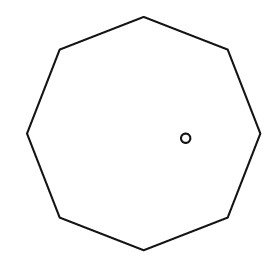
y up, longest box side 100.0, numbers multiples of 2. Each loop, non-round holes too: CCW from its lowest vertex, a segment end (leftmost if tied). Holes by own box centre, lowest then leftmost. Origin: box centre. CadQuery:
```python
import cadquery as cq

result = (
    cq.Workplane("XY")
    .moveTo(0.0, -50.0)
    .lineTo(36.0, -36.0)
    .lineTo(50.0, 0.0)
    .lineTo(36.0, 36.0)
    .lineTo(0.0, 50.0)
    .lineTo(-36.0, 36.0)
    .lineTo(-50.0, 0.0)
    .lineTo(-36.0, -36.0)
    .close()
    .moveTo(18.0, -2.0)
    .circle(2.0)
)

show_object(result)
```